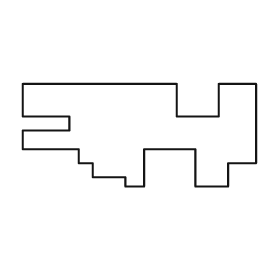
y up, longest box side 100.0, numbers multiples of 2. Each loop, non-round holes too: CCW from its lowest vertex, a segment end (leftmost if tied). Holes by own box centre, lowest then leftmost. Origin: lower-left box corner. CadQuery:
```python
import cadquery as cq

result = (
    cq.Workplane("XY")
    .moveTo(44.0, 0.0)
    .lineTo(52.0, 0.0)
    .lineTo(52.0, 16.0)
    .lineTo(74.0, 16.0)
    .lineTo(74.0, 0.0)
    .lineTo(88.0, 0.0)
    .lineTo(88.0, 10.0)
    .lineTo(100.0, 10.0)
    .lineTo(100.0, 44.0)
    .lineTo(84.0, 44.0)
    .lineTo(84.0, 30.0)
    .lineTo(66.0, 30.0)
    .lineTo(66.0, 44.0)
    .lineTo(0.0, 44.0)
    .lineTo(0.0, 30.0)
    .lineTo(20.0, 30.0)
    .lineTo(20.0, 24.0)
    .lineTo(0.0, 24.0)
    .lineTo(0.0, 16.0)
    .lineTo(24.0, 16.0)
    .lineTo(24.0, 10.0)
    .lineTo(30.0, 10.0)
    .lineTo(30.0, 4.0)
    .lineTo(44.0, 4.0)
    .close()
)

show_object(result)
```